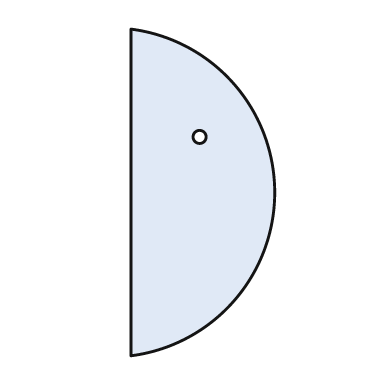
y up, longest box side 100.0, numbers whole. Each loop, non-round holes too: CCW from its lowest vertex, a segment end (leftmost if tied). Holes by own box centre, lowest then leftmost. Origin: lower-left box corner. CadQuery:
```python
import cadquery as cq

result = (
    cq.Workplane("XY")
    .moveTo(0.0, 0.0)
    .threePointArc((44.0, 50.0), (0.0, 100.0))
    .close()
    .moveTo(21.0, 67.0)
    .circle(2.0)
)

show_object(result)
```